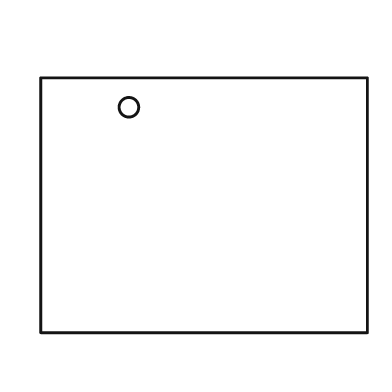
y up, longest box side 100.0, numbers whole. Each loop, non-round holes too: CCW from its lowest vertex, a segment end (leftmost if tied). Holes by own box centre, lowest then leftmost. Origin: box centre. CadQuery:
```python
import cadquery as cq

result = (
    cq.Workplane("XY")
    .moveTo(-50.0, -39.0)
    .lineTo(50.0, -39.0)
    .lineTo(50.0, 39.0)
    .lineTo(-50.0, 39.0)
    .close()
    .moveTo(-23.0, 30.0)
    .circle(3.0)
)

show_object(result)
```